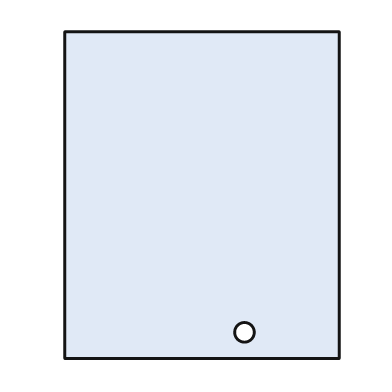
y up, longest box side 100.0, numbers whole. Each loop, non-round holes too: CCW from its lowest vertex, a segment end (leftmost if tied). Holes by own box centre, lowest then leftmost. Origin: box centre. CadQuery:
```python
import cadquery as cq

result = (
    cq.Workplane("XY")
    .moveTo(-42.0, -50.0)
    .lineTo(42.0, -50.0)
    .lineTo(42.0, 50.0)
    .lineTo(-42.0, 50.0)
    .close()
    .moveTo(13.0, -42.0)
    .circle(3.0)
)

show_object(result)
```